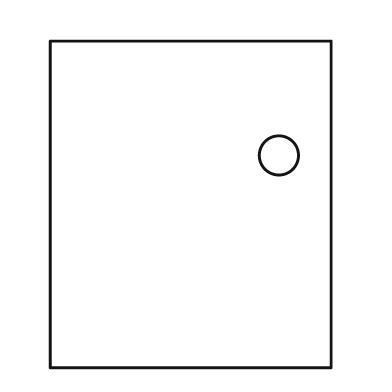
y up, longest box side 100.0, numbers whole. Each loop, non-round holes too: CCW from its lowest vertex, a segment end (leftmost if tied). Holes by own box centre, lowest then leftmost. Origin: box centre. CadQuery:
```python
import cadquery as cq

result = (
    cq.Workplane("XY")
    .moveTo(-43.0, -50.0)
    .lineTo(43.0, -50.0)
    .lineTo(43.0, 50.0)
    .lineTo(-43.0, 50.0)
    .close()
    .moveTo(27.0, 15.0)
    .circle(6.0)
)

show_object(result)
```